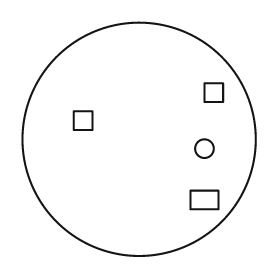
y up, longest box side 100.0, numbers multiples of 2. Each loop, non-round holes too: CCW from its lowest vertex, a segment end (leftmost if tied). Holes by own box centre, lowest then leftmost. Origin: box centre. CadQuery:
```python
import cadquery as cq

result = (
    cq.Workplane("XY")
    .moveTo(0.0, 0.0)
    .circle(50.0)
    .moveTo(22.0, -30.0)
    .lineTo(34.0, -30.0)
    .lineTo(34.0, -22.0)
    .lineTo(22.0, -22.0)
    .close()
    .moveTo(28.0, -4.0)
    .circle(4.0)
    .moveTo(-28.0, 4.0)
    .lineTo(-20.0, 4.0)
    .lineTo(-20.0, 12.0)
    .lineTo(-28.0, 12.0)
    .close()
    .moveTo(28.0, 16.0)
    .lineTo(36.0, 16.0)
    .lineTo(36.0, 24.0)
    .lineTo(28.0, 24.0)
    .close()
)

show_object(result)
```